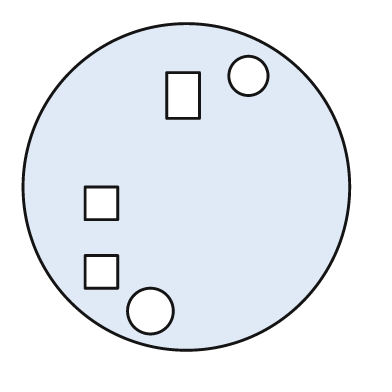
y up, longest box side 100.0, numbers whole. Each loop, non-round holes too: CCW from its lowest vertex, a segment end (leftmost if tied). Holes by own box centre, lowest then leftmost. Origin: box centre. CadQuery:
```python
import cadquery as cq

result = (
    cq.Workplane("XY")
    .moveTo(0.0, 0.0)
    .circle(50.0)
    .moveTo(-11.0, -38.0)
    .circle(7.0)
    .moveTo(-31.0, -31.0)
    .lineTo(-21.0, -31.0)
    .lineTo(-21.0, -21.0)
    .lineTo(-31.0, -21.0)
    .close()
    .moveTo(-31.0, -10.0)
    .lineTo(-21.0, -10.0)
    .lineTo(-21.0, 0.0)
    .lineTo(-31.0, 0.0)
    .close()
    .moveTo(-6.0, 21.0)
    .lineTo(4.0, 21.0)
    .lineTo(4.0, 35.0)
    .lineTo(-6.0, 35.0)
    .close()
    .moveTo(19.0, 34.0)
    .circle(6.0)
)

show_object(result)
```